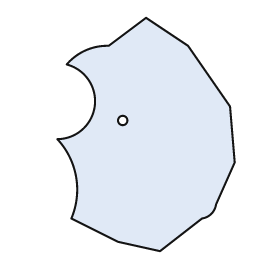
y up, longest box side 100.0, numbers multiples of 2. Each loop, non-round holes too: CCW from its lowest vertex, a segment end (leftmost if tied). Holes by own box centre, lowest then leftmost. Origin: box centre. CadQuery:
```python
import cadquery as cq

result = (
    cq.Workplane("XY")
    .moveTo(6.0, -50.0)
    .lineTo(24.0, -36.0)
    .threePointArc((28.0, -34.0), (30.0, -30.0))
    .lineTo(38.0, -12.0)
    .lineTo(36.0, 12.0)
    .lineTo(18.0, 38.0)
    .lineTo(0.0, 50.0)
    .lineTo(-16.0, 38.0)
    .threePointArc((-26.0, 36.0), (-34.0, 30.0))
    .threePointArc((-22.0, 12.0), (-38.0, -2.0))
    .threePointArc((-30.0, -18.0), (-32.0, -36.0))
    .lineTo(-12.0, -46.0)
    .close()
    .moveTo(-10.0, 6.0)
    .circle(2.0)
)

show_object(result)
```